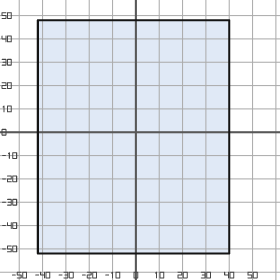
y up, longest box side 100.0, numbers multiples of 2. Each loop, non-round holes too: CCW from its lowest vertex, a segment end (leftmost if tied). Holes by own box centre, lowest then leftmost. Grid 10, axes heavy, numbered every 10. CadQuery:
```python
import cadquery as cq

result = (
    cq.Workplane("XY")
    .moveTo(-42.0, -52.0)
    .lineTo(40.0, -52.0)
    .lineTo(40.0, 48.0)
    .lineTo(-42.0, 48.0)
    .close()
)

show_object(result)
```